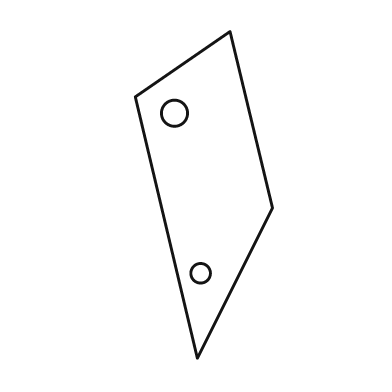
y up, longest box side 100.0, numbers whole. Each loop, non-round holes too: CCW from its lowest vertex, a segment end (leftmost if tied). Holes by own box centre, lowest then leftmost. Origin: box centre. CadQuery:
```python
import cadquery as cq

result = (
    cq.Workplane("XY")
    .moveTo(-2.0, -50.0)
    .lineTo(21.0, -4.0)
    .lineTo(8.0, 50.0)
    .lineTo(-21.0, 30.0)
    .close()
    .moveTo(-1.0, -24.0)
    .circle(3.0)
    .moveTo(-9.0, 25.0)
    .circle(4.0)
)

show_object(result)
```